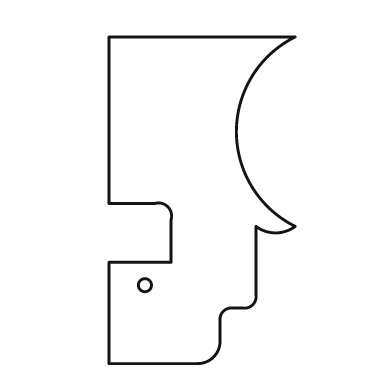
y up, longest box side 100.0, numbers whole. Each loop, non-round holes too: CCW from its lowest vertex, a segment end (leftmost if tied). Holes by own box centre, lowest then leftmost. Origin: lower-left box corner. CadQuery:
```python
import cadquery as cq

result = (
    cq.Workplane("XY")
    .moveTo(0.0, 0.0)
    .lineTo(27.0, 0.0)
    .threePointArc((32.0, 2.0), (34.0, 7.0))
    .lineTo(34.0, 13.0)
    .threePointArc((35.0, 16.0), (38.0, 17.0))
    .lineTo(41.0, 17.0)
    .threePointArc((44.0, 18.0), (45.0, 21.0))
    .lineTo(45.0, 42.0)
    .threePointArc((51.0, 40.0), (57.0, 42.0))
    .threePointArc((39.0, 71.0), (57.0, 100.0))
    .lineTo(0.0, 100.0)
    .lineTo(0.0, 49.0)
    .lineTo(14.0, 49.0)
    .threePointArc((18.0, 48.0), (19.0, 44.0))
    .lineTo(19.0, 31.0)
    .lineTo(0.0, 31.0)
    .close()
    .moveTo(11.0, 24.0)
    .circle(2.0)
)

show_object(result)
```